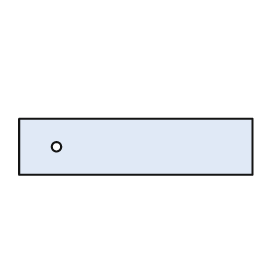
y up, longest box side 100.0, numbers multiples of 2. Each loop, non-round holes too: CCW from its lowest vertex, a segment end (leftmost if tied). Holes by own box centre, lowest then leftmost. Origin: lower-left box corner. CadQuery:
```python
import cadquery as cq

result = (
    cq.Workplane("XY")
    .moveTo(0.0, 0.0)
    .lineTo(100.0, 0.0)
    .lineTo(100.0, 24.0)
    .lineTo(0.0, 24.0)
    .close()
    .moveTo(16.0, 12.0)
    .circle(2.0)
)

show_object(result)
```